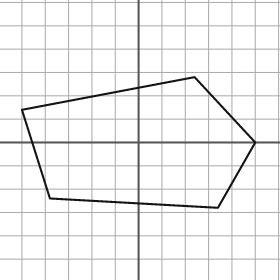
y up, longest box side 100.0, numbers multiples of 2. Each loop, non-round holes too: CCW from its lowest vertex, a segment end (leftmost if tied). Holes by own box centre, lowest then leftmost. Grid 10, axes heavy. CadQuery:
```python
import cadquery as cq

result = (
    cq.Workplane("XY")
    .moveTo(34.0, -28.0)
    .lineTo(50.0, 0.0)
    .lineTo(24.0, 28.0)
    .lineTo(-50.0, 14.0)
    .lineTo(-38.0, -24.0)
    .close()
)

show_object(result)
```